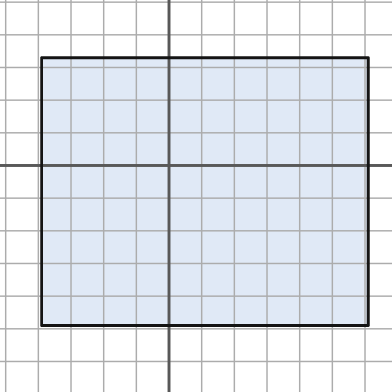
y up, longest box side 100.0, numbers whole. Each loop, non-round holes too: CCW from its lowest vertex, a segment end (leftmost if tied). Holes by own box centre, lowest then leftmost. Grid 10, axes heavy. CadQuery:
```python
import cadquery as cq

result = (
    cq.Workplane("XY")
    .moveTo(-39.0, -49.0)
    .lineTo(61.0, -49.0)
    .lineTo(61.0, 33.0)
    .lineTo(-39.0, 33.0)
    .close()
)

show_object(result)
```